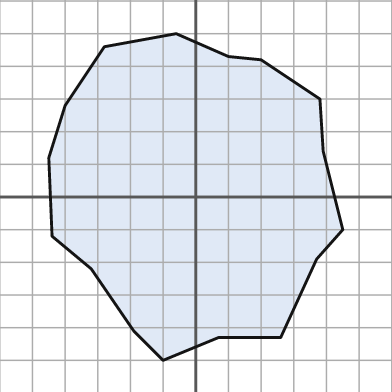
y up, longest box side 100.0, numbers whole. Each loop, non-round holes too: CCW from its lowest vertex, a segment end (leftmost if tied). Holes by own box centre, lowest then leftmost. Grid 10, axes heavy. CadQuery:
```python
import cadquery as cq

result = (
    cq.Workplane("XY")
    .moveTo(-10.0, -50.0)
    .lineTo(7.0, -43.0)
    .lineTo(26.0, -43.0)
    .lineTo(37.0, -19.0)
    .lineTo(45.0, -10.0)
    .lineTo(39.0, 14.0)
    .lineTo(38.0, 30.0)
    .lineTo(20.0, 42.0)
    .lineTo(10.0, 43.0)
    .lineTo(-6.0, 50.0)
    .lineTo(-28.0, 46.0)
    .lineTo(-40.0, 28.0)
    .lineTo(-45.0, 12.0)
    .lineTo(-44.0, -12.0)
    .lineTo(-32.0, -22.0)
    .lineTo(-19.0, -41.0)
    .close()
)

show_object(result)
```